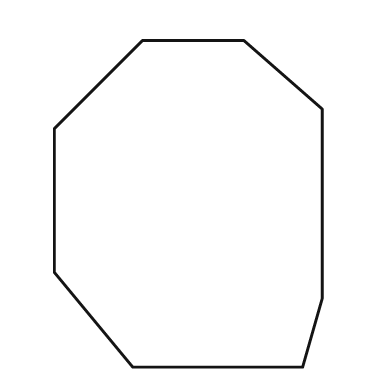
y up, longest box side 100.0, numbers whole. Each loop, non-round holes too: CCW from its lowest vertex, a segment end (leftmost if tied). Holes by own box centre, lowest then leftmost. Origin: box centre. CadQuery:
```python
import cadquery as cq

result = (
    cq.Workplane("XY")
    .moveTo(-17.0, -50.0)
    .lineTo(35.0, -50.0)
    .lineTo(41.0, -29.0)
    .lineTo(41.0, 29.0)
    .lineTo(17.0, 50.0)
    .lineTo(-14.0, 50.0)
    .lineTo(-41.0, 23.0)
    .lineTo(-41.0, -21.0)
    .close()
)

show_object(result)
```